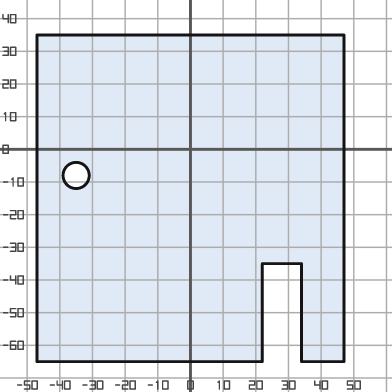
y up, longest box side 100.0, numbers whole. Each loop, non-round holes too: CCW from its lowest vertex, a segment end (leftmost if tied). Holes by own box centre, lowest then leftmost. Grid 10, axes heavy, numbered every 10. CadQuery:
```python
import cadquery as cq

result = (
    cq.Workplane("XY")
    .moveTo(-47.0, -65.0)
    .lineTo(22.0, -65.0)
    .lineTo(22.0, -35.0)
    .lineTo(34.0, -35.0)
    .lineTo(34.0, -65.0)
    .lineTo(47.0, -65.0)
    .lineTo(47.0, 35.0)
    .lineTo(-47.0, 35.0)
    .close()
    .moveTo(-35.0, -8.0)
    .circle(4.0)
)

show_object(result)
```